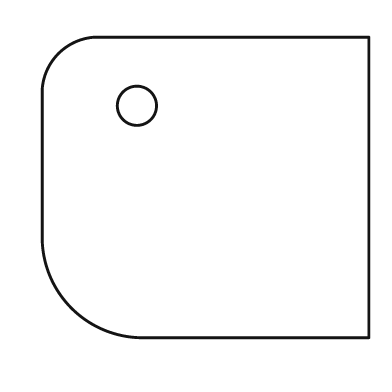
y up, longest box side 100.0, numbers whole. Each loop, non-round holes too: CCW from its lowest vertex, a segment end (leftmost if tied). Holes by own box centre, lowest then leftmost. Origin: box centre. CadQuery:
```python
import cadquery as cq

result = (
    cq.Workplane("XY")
    .moveTo(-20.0, -46.0)
    .lineTo(50.0, -46.0)
    .lineTo(50.0, 46.0)
    .lineTo(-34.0, 46.0)
    .threePointArc((-45.0, 41.0), (-50.0, 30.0))
    .lineTo(-50.0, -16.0)
    .threePointArc((-41.0, -37.0), (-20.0, -46.0))
    .close()
    .moveTo(-21.0, 25.0)
    .circle(6.0)
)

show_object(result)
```